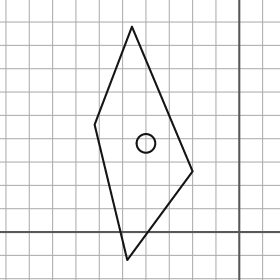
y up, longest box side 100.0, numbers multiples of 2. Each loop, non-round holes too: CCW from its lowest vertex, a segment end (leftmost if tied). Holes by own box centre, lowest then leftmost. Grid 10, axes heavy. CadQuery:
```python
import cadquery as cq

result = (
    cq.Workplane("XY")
    .moveTo(-48.0, -12.0)
    .lineTo(-20.0, 26.0)
    .lineTo(-46.0, 88.0)
    .lineTo(-62.0, 46.0)
    .close()
    .moveTo(-40.0, 38.0)
    .circle(4.0)
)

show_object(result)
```